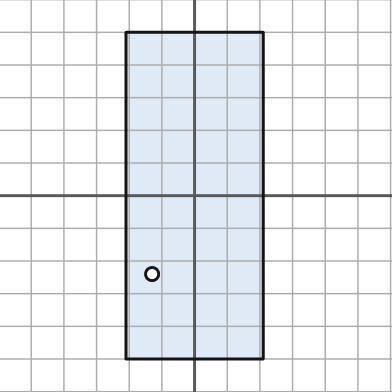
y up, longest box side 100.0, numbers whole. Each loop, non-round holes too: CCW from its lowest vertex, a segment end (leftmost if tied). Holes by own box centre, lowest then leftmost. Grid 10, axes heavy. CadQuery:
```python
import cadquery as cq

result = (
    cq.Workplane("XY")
    .moveTo(-21.0, -50.0)
    .lineTo(21.0, -50.0)
    .lineTo(21.0, 50.0)
    .lineTo(-21.0, 50.0)
    .close()
    .moveTo(-13.0, -24.0)
    .circle(2.0)
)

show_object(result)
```